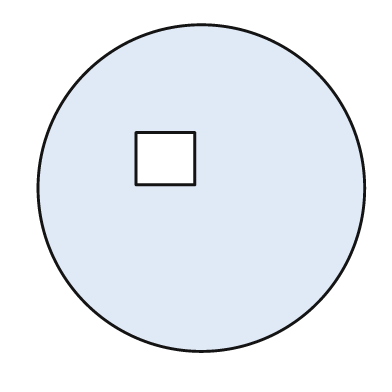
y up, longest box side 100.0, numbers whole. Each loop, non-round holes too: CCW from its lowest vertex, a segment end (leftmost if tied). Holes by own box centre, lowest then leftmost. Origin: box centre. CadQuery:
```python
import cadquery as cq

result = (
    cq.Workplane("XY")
    .moveTo(0.0, 0.0)
    .circle(50.0)
    .moveTo(-20.0, 1.0)
    .lineTo(-2.0, 1.0)
    .lineTo(-2.0, 17.0)
    .lineTo(-20.0, 17.0)
    .close()
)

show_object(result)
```